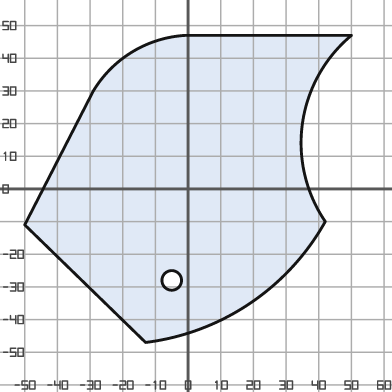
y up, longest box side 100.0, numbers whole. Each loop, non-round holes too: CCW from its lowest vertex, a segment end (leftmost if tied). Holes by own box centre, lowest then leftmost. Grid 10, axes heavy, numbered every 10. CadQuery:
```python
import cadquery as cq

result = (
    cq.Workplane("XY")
    .moveTo(-13.0, -47.0)
    .threePointArc((19.0, -35.0), (42.0, -10.0))
    .threePointArc((35.0, 20.0), (50.0, 47.0))
    .lineTo(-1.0, 47.0)
    .threePointArc((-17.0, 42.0), (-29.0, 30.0))
    .lineTo(-50.0, -11.0)
    .close()
    .moveTo(-5.0, -28.0)
    .circle(3.0)
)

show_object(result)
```